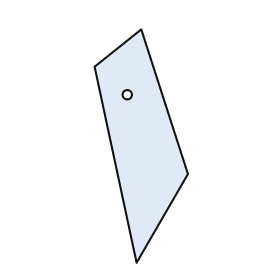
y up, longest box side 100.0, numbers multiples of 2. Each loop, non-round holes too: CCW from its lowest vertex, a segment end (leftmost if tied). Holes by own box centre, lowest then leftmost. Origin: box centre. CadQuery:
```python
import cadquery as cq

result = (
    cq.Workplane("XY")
    .moveTo(-2.0, -50.0)
    .lineTo(20.0, -12.0)
    .lineTo(0.0, 50.0)
    .lineTo(-20.0, 34.0)
    .close()
    .moveTo(-6.0, 22.0)
    .circle(2.0)
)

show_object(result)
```